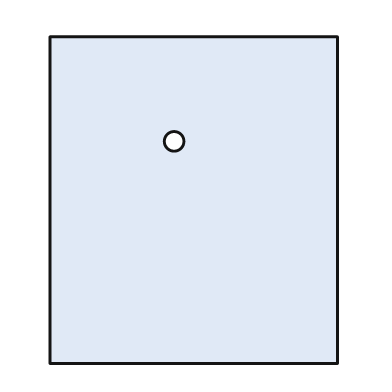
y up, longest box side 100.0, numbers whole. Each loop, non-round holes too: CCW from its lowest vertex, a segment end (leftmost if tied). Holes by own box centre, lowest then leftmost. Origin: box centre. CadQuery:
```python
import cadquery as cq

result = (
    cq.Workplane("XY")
    .moveTo(-44.0, -50.0)
    .lineTo(44.0, -50.0)
    .lineTo(44.0, 50.0)
    .lineTo(-44.0, 50.0)
    .close()
    .moveTo(-6.0, 18.0)
    .circle(3.0)
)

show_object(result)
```